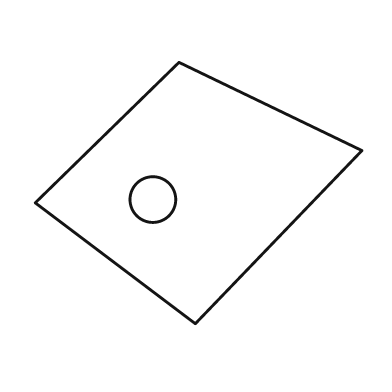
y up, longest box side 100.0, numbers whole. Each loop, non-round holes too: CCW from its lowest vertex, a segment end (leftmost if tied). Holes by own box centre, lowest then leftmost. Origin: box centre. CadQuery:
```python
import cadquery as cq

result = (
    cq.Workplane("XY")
    .moveTo(-1.0, -40.0)
    .lineTo(50.0, 13.0)
    .lineTo(-6.0, 40.0)
    .lineTo(-50.0, -3.0)
    .close()
    .moveTo(-14.0, -2.0)
    .circle(7.0)
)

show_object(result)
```